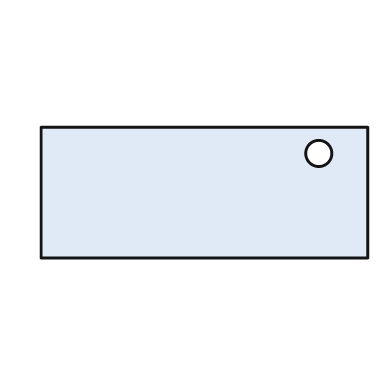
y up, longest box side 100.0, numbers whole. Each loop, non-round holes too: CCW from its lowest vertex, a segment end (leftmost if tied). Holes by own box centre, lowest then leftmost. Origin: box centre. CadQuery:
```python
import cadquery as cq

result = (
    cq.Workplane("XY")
    .moveTo(-50.0, -20.0)
    .lineTo(50.0, -20.0)
    .lineTo(50.0, 20.0)
    .lineTo(-50.0, 20.0)
    .close()
    .moveTo(35.0, 12.0)
    .circle(4.0)
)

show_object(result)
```